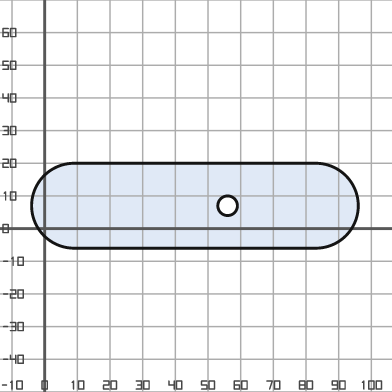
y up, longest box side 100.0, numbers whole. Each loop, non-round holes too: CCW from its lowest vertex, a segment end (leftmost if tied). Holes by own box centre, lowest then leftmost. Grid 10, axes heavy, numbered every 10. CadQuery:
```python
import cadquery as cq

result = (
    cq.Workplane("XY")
    .moveTo(9.0, -6.0)
    .lineTo(83.0, -6.0)
    .threePointArc((96.0, 7.0), (83.0, 20.0))
    .lineTo(9.0, 20.0)
    .threePointArc((-4.0, 7.0), (9.0, -6.0))
    .close()
    .moveTo(56.0, 7.0)
    .circle(3.0)
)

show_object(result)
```